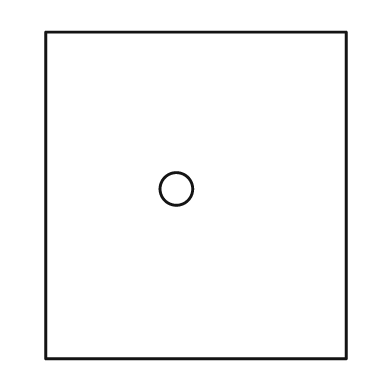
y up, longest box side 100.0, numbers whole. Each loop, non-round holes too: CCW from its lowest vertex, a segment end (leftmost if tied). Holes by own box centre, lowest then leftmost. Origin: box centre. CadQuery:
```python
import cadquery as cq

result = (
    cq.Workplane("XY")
    .moveTo(-46.0, -50.0)
    .lineTo(46.0, -50.0)
    .lineTo(46.0, 50.0)
    .lineTo(-46.0, 50.0)
    .close()
    .moveTo(-6.0, 2.0)
    .circle(5.0)
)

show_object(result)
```